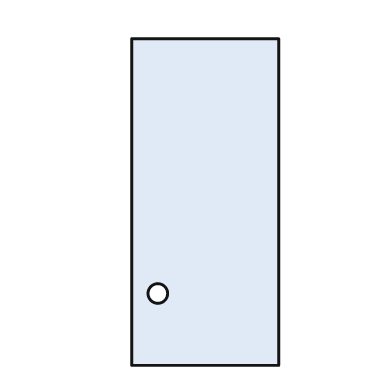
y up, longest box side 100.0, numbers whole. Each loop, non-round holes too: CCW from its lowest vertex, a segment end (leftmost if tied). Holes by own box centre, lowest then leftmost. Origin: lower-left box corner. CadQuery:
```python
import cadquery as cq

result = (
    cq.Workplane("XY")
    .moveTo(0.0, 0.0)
    .lineTo(45.0, 0.0)
    .lineTo(45.0, 100.0)
    .lineTo(0.0, 100.0)
    .close()
    .moveTo(8.0, 22.0)
    .circle(3.0)
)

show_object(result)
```